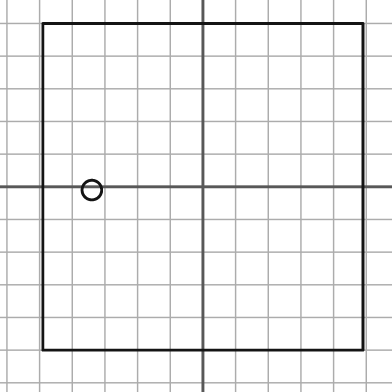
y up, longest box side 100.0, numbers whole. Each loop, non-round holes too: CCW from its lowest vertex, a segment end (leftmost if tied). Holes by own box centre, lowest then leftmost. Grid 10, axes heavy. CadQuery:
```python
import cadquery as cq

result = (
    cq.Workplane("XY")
    .moveTo(-49.0, -50.0)
    .lineTo(49.0, -50.0)
    .lineTo(49.0, 50.0)
    .lineTo(-49.0, 50.0)
    .close()
    .moveTo(-34.0, -1.0)
    .circle(3.0)
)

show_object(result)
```